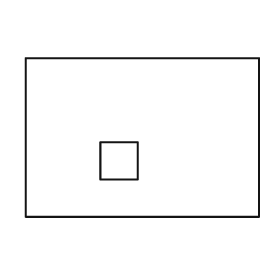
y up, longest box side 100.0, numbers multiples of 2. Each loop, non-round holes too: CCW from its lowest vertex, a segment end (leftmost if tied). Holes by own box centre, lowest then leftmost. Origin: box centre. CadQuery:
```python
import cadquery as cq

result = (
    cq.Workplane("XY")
    .moveTo(-50.0, -34.0)
    .lineTo(50.0, -34.0)
    .lineTo(50.0, 34.0)
    .lineTo(-50.0, 34.0)
    .close()
    .moveTo(-18.0, -18.0)
    .lineTo(-2.0, -18.0)
    .lineTo(-2.0, -2.0)
    .lineTo(-18.0, -2.0)
    .close()
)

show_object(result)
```